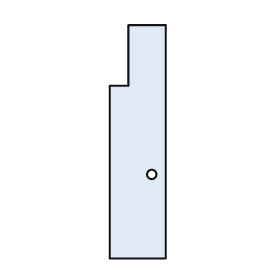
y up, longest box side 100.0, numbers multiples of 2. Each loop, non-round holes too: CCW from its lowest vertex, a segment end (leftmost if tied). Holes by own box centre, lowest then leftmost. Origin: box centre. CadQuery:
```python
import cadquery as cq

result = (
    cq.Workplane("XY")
    .moveTo(-12.0, -50.0)
    .lineTo(12.0, -50.0)
    .lineTo(12.0, 50.0)
    .lineTo(-4.0, 50.0)
    .lineTo(-4.0, 24.0)
    .lineTo(-12.0, 24.0)
    .close()
    .moveTo(6.0, -14.0)
    .circle(2.0)
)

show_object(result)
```